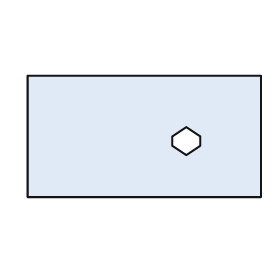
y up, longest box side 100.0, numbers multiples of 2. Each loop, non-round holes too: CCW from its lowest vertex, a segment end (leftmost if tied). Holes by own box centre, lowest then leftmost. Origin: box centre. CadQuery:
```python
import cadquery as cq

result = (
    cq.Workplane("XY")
    .moveTo(-50.0, -26.0)
    .lineTo(50.0, -26.0)
    .lineTo(50.0, 26.0)
    .lineTo(-50.0, 26.0)
    .close()
    .moveTo(18.0, -8.0)
    .lineTo(24.0, -4.0)
    .lineTo(24.0, 0.0)
    .lineTo(18.0, 4.0)
    .lineTo(12.0, 0.0)
    .lineTo(12.0, -4.0)
    .close()
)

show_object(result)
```